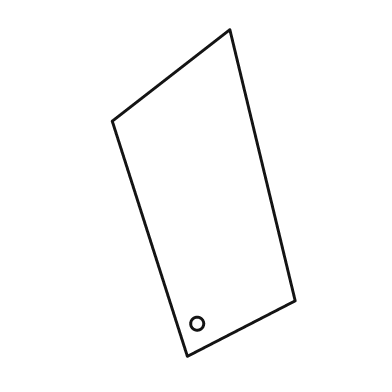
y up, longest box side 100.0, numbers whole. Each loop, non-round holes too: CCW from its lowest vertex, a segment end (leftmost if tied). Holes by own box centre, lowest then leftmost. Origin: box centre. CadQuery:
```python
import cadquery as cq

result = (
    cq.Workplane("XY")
    .moveTo(-5.0, -50.0)
    .lineTo(28.0, -33.0)
    .lineTo(8.0, 50.0)
    .lineTo(-28.0, 22.0)
    .close()
    .moveTo(-2.0, -40.0)
    .circle(2.0)
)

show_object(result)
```